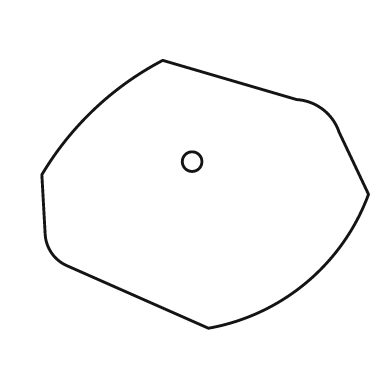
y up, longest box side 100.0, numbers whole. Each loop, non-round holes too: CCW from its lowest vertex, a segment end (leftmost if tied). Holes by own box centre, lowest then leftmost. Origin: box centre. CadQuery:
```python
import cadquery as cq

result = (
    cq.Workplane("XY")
    .moveTo(1.0, -41.0)
    .threePointArc((31.0, -27.0), (50.0, 0.0))
    .lineTo(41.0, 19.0)
    .threePointArc((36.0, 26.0), (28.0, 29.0))
    .lineTo(-13.0, 41.0)
    .threePointArc((-34.0, 26.0), (-50.0, 6.0))
    .lineTo(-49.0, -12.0)
    .threePointArc((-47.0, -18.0), (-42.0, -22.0))
    .close()
    .moveTo(-4.0, 10.0)
    .circle(3.0)
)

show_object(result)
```